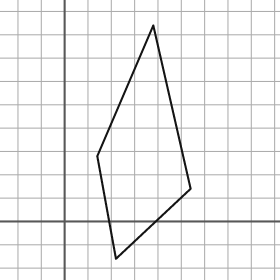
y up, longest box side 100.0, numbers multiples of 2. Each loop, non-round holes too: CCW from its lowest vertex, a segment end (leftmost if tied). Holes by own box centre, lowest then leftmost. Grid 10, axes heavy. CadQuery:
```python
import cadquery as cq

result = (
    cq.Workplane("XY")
    .moveTo(22.0, -16.0)
    .lineTo(54.0, 14.0)
    .lineTo(38.0, 84.0)
    .lineTo(14.0, 28.0)
    .close()
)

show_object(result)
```